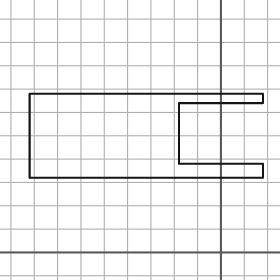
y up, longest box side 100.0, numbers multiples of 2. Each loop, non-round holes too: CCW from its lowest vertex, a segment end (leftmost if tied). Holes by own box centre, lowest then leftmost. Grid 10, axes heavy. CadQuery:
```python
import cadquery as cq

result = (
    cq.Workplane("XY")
    .moveTo(-82.0, 32.0)
    .lineTo(18.0, 32.0)
    .lineTo(18.0, 38.0)
    .lineTo(-18.0, 38.0)
    .lineTo(-18.0, 64.0)
    .lineTo(18.0, 64.0)
    .lineTo(18.0, 68.0)
    .lineTo(-82.0, 68.0)
    .close()
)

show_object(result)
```